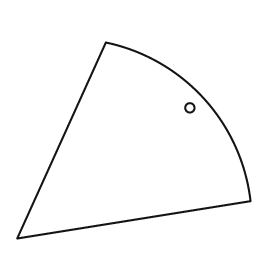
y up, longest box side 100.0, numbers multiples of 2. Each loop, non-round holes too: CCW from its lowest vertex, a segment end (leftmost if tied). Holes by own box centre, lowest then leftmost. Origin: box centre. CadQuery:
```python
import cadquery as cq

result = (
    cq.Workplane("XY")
    .moveTo(-50.0, -42.0)
    .lineTo(50.0, -26.0)
    .threePointArc((30.0, 18.0), (-12.0, 42.0))
    .close()
    .moveTo(24.0, 14.0)
    .circle(2.0)
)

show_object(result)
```